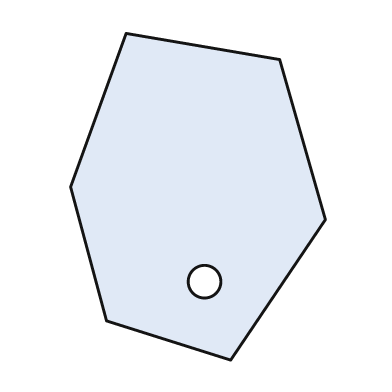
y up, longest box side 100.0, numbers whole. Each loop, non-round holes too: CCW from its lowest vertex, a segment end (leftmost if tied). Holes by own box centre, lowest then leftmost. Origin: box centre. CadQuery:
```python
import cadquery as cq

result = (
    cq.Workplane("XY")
    .moveTo(10.0, -50.0)
    .lineTo(39.0, -7.0)
    .lineTo(25.0, 42.0)
    .lineTo(-22.0, 50.0)
    .lineTo(-39.0, 3.0)
    .lineTo(-28.0, -38.0)
    .close()
    .moveTo(2.0, -26.0)
    .circle(5.0)
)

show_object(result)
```